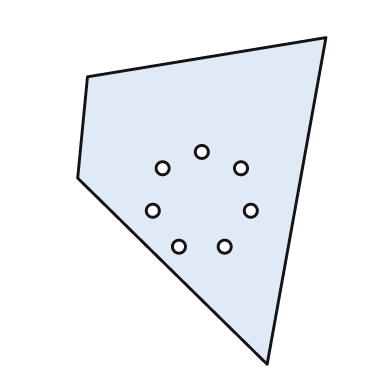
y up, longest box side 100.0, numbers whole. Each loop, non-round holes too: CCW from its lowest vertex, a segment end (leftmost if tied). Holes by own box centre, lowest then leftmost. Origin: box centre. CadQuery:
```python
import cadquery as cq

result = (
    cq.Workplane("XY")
    .moveTo(20.0, -50.0)
    .lineTo(38.0, 50.0)
    .lineTo(-35.0, 38.0)
    .lineTo(-38.0, 7.0)
    .close()
    .moveTo(-7.0, -14.0)
    .circle(2.0)
    .moveTo(7.0, -14.0)
    .circle(2.0)
    .moveTo(-15.0, -3.0)
    .circle(2.0)
    .moveTo(15.0, -3.0)
    .circle(2.0)
    .moveTo(-12.0, 10.0)
    .circle(2.0)
    .moveTo(12.0, 10.0)
    .circle(2.0)
    .moveTo(0.0, 15.0)
    .circle(2.0)
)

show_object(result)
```